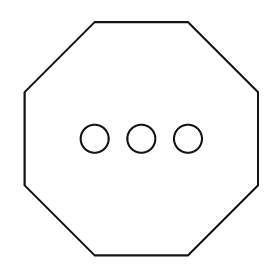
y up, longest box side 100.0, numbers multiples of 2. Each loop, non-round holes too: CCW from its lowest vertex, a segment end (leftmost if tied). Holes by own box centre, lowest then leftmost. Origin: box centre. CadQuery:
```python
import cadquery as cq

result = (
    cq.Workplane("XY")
    .moveTo(-20.0, -50.0)
    .lineTo(20.0, -50.0)
    .lineTo(50.0, -20.0)
    .lineTo(50.0, 20.0)
    .lineTo(20.0, 50.0)
    .lineTo(-20.0, 50.0)
    .lineTo(-50.0, 20.0)
    .lineTo(-50.0, -20.0)
    .close()
    .moveTo(-20.0, 0.0)
    .circle(6.0)
    .moveTo(0.0, 0.0)
    .circle(6.0)
    .moveTo(20.0, 0.0)
    .circle(6.0)
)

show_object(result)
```